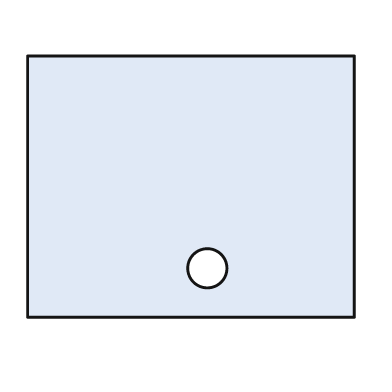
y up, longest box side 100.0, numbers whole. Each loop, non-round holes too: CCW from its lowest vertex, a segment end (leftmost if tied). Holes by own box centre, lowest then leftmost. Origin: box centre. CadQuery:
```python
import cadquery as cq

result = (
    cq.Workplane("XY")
    .moveTo(-50.0, -40.0)
    .lineTo(50.0, -40.0)
    .lineTo(50.0, 40.0)
    .lineTo(-50.0, 40.0)
    .close()
    .moveTo(5.0, -25.0)
    .circle(6.0)
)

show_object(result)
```